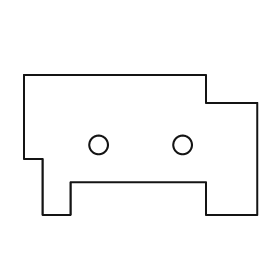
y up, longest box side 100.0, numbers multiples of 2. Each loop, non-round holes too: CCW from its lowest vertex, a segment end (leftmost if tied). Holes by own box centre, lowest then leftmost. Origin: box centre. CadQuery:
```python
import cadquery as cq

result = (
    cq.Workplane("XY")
    .moveTo(-42.0, -30.0)
    .lineTo(-30.0, -30.0)
    .lineTo(-30.0, -16.0)
    .lineTo(28.0, -16.0)
    .lineTo(28.0, -30.0)
    .lineTo(50.0, -30.0)
    .lineTo(50.0, 18.0)
    .lineTo(28.0, 18.0)
    .lineTo(28.0, 30.0)
    .lineTo(-50.0, 30.0)
    .lineTo(-50.0, -6.0)
    .lineTo(-42.0, -6.0)
    .close()
    .moveTo(-18.0, 0.0)
    .circle(4.0)
    .moveTo(18.0, 0.0)
    .circle(4.0)
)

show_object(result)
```